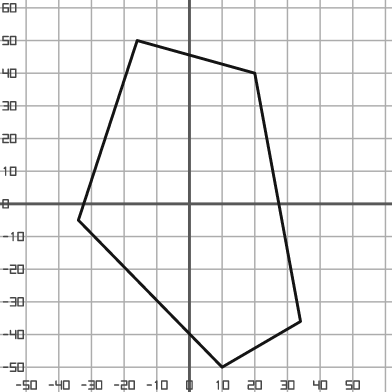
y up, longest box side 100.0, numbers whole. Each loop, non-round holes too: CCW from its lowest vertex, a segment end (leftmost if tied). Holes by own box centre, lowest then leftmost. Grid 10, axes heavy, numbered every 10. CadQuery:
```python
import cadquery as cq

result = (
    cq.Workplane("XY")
    .moveTo(10.0, -50.0)
    .lineTo(34.0, -36.0)
    .lineTo(20.0, 40.0)
    .lineTo(-16.0, 50.0)
    .lineTo(-34.0, -5.0)
    .close()
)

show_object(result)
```